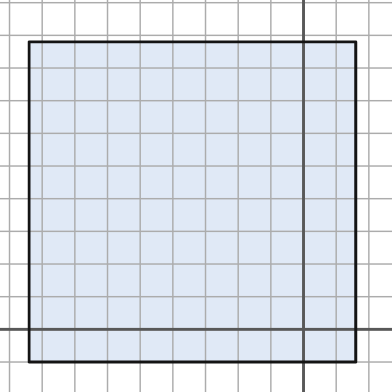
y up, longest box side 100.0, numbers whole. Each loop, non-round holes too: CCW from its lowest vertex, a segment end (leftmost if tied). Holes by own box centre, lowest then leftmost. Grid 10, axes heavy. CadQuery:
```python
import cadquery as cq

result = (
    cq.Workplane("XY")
    .moveTo(-84.0, -10.0)
    .lineTo(16.0, -10.0)
    .lineTo(16.0, 88.0)
    .lineTo(-84.0, 88.0)
    .close()
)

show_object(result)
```